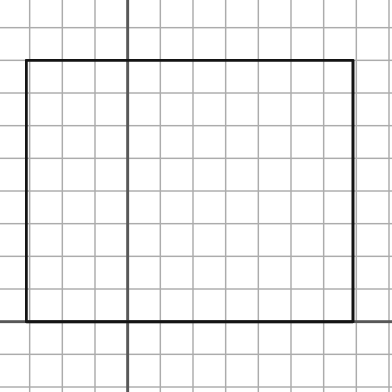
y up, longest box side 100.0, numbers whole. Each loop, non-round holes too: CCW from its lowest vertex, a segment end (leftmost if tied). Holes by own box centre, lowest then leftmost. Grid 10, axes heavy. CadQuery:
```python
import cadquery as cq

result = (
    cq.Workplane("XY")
    .moveTo(-31.0, 0.0)
    .lineTo(69.0, 0.0)
    .lineTo(69.0, 80.0)
    .lineTo(-31.0, 80.0)
    .close()
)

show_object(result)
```